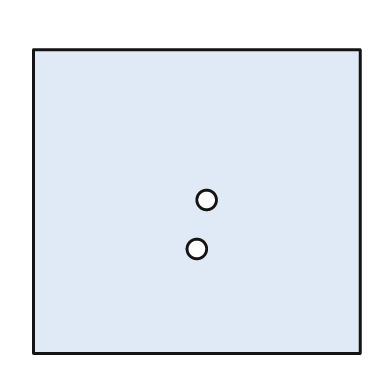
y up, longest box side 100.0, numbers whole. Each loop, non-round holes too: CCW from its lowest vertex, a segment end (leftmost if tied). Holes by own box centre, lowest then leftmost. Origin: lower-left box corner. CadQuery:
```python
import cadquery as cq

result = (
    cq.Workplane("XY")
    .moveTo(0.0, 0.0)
    .lineTo(100.0, 0.0)
    .lineTo(100.0, 93.0)
    .lineTo(0.0, 93.0)
    .close()
    .moveTo(50.0, 32.0)
    .circle(3.0)
    .moveTo(53.0, 47.0)
    .circle(3.0)
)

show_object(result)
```